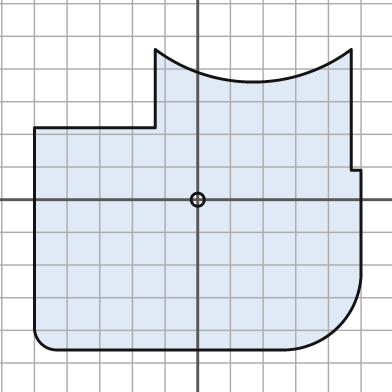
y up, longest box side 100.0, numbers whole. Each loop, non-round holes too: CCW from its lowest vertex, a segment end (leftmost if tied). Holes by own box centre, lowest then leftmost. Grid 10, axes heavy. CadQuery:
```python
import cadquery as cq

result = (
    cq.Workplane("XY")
    .moveTo(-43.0, -46.0)
    .lineTo(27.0, -46.0)
    .threePointArc((43.0, -39.0), (50.0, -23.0))
    .lineTo(50.0, 9.0)
    .lineTo(47.0, 9.0)
    .lineTo(47.0, 46.0)
    .threePointArc((17.0, 36.0), (-13.0, 46.0))
    .lineTo(-13.0, 22.0)
    .lineTo(-50.0, 22.0)
    .lineTo(-50.0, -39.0)
    .threePointArc((-48.0, -44.0), (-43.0, -46.0))
    .close()
    .moveTo(0.0, 0.0)
    .circle(2.0)
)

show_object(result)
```